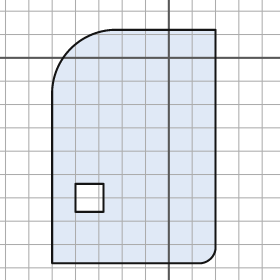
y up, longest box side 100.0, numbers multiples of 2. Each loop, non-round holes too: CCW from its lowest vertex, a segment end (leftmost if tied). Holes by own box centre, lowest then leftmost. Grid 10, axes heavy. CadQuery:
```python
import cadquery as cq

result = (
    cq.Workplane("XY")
    .moveTo(-50.0, -88.0)
    .lineTo(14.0, -88.0)
    .threePointArc((18.0, -86.0), (20.0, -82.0))
    .lineTo(20.0, 12.0)
    .lineTo(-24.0, 12.0)
    .threePointArc((-42.0, 4.0), (-50.0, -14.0))
    .close()
    .moveTo(-40.0, -66.0)
    .lineTo(-28.0, -66.0)
    .lineTo(-28.0, -54.0)
    .lineTo(-40.0, -54.0)
    .close()
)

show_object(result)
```